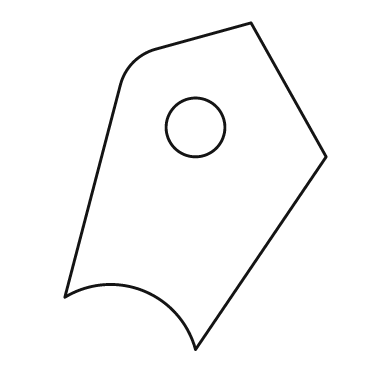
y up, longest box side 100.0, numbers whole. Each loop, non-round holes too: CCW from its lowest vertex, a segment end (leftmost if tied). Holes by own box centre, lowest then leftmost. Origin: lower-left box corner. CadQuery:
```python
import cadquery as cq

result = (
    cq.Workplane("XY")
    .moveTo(40.0, 0.0)
    .lineTo(80.0, 59.0)
    .lineTo(57.0, 100.0)
    .lineTo(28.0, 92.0)
    .threePointArc((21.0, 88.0), (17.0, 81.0))
    .lineTo(0.0, 16.0)
    .threePointArc((24.0, 18.0), (40.0, 0.0))
    .close()
    .moveTo(40.0, 68.0)
    .circle(9.0)
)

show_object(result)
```